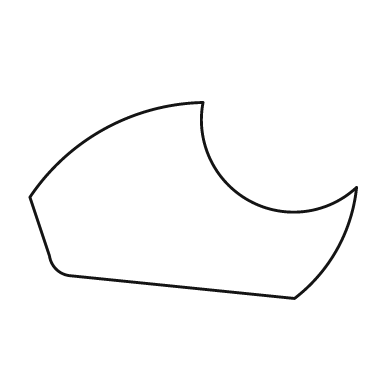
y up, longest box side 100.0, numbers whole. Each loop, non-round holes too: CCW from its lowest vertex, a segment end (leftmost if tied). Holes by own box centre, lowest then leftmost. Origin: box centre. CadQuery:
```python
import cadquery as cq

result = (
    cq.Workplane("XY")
    .moveTo(31.0, -30.0)
    .threePointArc((44.0, -15.0), (50.0, 4.0))
    .threePointArc((17.0, 0.0), (3.0, 30.0))
    .threePointArc((-27.0, 22.0), (-50.0, 1.0))
    .lineTo(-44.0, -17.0)
    .threePointArc((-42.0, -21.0), (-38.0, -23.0))
    .close()
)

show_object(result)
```